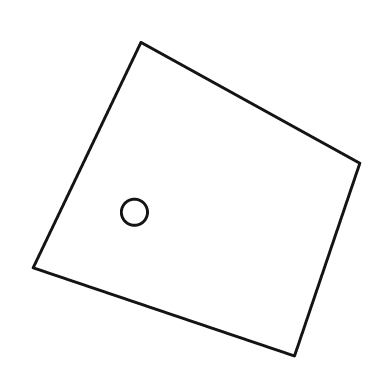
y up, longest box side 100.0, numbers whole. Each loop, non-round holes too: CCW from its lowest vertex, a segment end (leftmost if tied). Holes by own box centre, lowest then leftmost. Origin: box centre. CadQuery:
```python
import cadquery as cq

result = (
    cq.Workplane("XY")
    .moveTo(30.0, -48.0)
    .lineTo(50.0, 11.0)
    .lineTo(-17.0, 48.0)
    .lineTo(-50.0, -21.0)
    .close()
    .moveTo(-19.0, -4.0)
    .circle(4.0)
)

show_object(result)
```